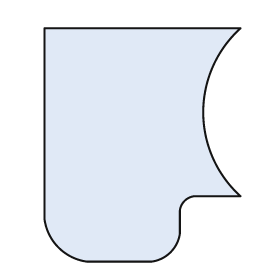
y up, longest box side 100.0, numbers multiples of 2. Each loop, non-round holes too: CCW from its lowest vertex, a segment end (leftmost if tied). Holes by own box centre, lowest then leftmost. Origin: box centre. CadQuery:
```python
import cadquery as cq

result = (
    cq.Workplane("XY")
    .moveTo(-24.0, -50.0)
    .lineTo(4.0, -50.0)
    .threePointArc((12.0, -46.0), (16.0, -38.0))
    .lineTo(16.0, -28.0)
    .threePointArc((18.0, -24.0), (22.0, -22.0))
    .lineTo(42.0, -22.0)
    .threePointArc((26.0, 14.0), (42.0, 50.0))
    .lineTo(-42.0, 50.0)
    .lineTo(-42.0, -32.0)
    .threePointArc((-36.0, -44.0), (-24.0, -50.0))
    .close()
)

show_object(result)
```